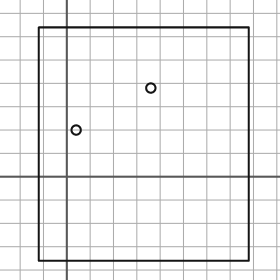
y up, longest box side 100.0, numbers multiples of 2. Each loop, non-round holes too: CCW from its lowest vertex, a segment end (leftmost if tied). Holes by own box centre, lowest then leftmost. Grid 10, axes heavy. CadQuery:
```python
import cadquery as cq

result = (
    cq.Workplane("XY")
    .moveTo(-12.0, -36.0)
    .lineTo(78.0, -36.0)
    .lineTo(78.0, 64.0)
    .lineTo(-12.0, 64.0)
    .close()
    .moveTo(4.0, 20.0)
    .circle(2.0)
    .moveTo(36.0, 38.0)
    .circle(2.0)
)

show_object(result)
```